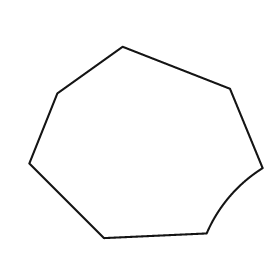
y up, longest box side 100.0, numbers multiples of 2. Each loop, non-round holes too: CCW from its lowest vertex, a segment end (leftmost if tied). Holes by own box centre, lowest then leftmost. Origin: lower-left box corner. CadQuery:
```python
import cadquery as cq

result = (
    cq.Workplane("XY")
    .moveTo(32.0, 0.0)
    .lineTo(76.0, 2.0)
    .threePointArc((86.0, 18.0), (100.0, 30.0))
    .lineTo(86.0, 64.0)
    .lineTo(40.0, 82.0)
    .lineTo(12.0, 62.0)
    .lineTo(0.0, 32.0)
    .close()
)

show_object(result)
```